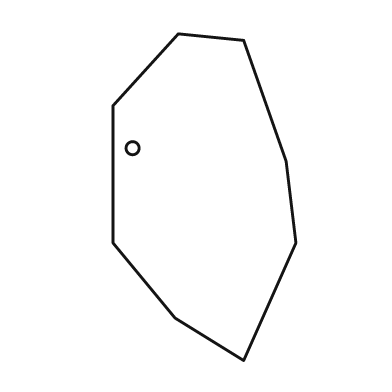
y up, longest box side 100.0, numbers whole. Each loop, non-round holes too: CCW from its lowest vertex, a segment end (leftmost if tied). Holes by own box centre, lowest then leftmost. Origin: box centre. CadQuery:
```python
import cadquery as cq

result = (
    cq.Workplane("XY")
    .moveTo(12.0, -50.0)
    .lineTo(28.0, -14.0)
    .lineTo(25.0, 11.0)
    .lineTo(12.0, 48.0)
    .lineTo(-8.0, 50.0)
    .lineTo(-28.0, 28.0)
    .lineTo(-28.0, -14.0)
    .lineTo(-9.0, -37.0)
    .close()
    .moveTo(-22.0, 15.0)
    .circle(2.0)
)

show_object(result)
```